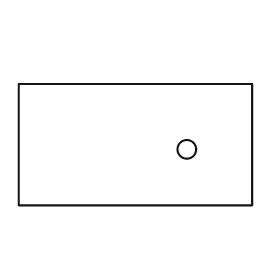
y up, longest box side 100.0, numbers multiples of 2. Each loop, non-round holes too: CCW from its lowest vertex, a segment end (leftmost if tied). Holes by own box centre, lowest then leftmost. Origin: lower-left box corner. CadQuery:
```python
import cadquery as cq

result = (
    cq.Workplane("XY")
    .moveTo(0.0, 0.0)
    .lineTo(100.0, 0.0)
    .lineTo(100.0, 52.0)
    .lineTo(0.0, 52.0)
    .close()
    .moveTo(72.0, 24.0)
    .circle(4.0)
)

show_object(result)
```